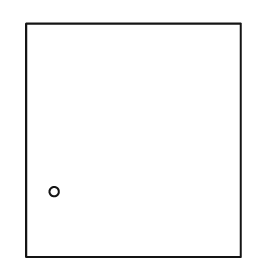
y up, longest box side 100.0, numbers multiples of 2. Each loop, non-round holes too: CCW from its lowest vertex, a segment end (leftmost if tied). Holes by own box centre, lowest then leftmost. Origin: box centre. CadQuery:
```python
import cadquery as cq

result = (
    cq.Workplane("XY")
    .moveTo(-46.0, -50.0)
    .lineTo(46.0, -50.0)
    .lineTo(46.0, 50.0)
    .lineTo(-46.0, 50.0)
    .close()
    .moveTo(-34.0, -22.0)
    .circle(2.0)
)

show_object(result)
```